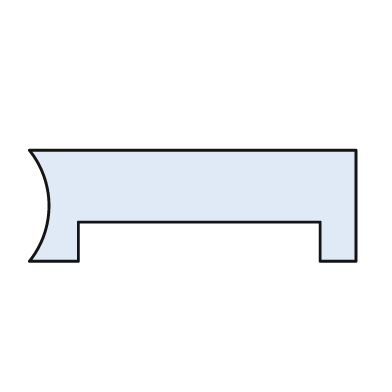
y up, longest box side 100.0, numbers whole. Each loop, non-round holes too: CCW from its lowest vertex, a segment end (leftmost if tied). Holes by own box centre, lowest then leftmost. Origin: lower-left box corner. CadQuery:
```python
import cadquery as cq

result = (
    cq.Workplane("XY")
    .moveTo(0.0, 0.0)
    .lineTo(15.0, 0.0)
    .lineTo(15.0, 12.0)
    .lineTo(89.0, 12.0)
    .lineTo(89.0, 0.0)
    .lineTo(100.0, 0.0)
    .lineTo(100.0, 34.0)
    .lineTo(0.0, 34.0)
    .threePointArc((6.0, 17.0), (0.0, 0.0))
    .close()
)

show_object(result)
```